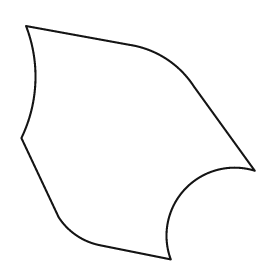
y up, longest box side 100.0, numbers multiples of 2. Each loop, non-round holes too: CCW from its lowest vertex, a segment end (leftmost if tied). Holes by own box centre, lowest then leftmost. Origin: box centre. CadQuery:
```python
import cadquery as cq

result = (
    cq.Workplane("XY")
    .moveTo(14.0, -50.0)
    .threePointArc((20.0, -20.0), (50.0, -12.0))
    .lineTo(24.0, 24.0)
    .threePointArc((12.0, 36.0), (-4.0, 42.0))
    .lineTo(-48.0, 50.0)
    .threePointArc((-44.0, 26.0), (-50.0, 2.0))
    .lineTo(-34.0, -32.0)
    .threePointArc((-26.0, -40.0), (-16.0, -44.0))
    .close()
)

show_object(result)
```